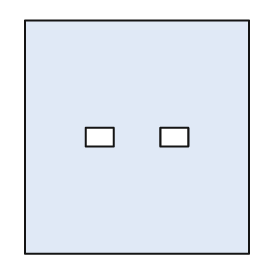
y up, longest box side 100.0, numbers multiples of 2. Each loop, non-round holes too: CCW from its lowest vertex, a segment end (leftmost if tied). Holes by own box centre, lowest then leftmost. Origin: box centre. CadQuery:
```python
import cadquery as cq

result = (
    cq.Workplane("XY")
    .moveTo(-48.0, -50.0)
    .lineTo(48.0, -50.0)
    .lineTo(48.0, 50.0)
    .lineTo(-48.0, 50.0)
    .close()
    .moveTo(-22.0, -4.0)
    .lineTo(-10.0, -4.0)
    .lineTo(-10.0, 4.0)
    .lineTo(-22.0, 4.0)
    .close()
    .moveTo(10.0, -4.0)
    .lineTo(22.0, -4.0)
    .lineTo(22.0, 4.0)
    .lineTo(10.0, 4.0)
    .close()
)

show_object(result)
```